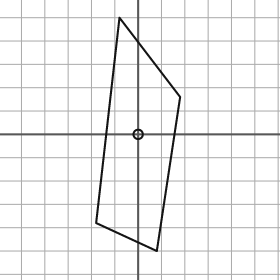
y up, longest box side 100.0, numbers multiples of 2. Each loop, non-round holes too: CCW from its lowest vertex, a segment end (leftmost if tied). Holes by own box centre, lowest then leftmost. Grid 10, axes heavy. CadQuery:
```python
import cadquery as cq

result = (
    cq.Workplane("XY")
    .moveTo(8.0, -50.0)
    .lineTo(18.0, 16.0)
    .lineTo(-8.0, 50.0)
    .lineTo(-18.0, -38.0)
    .close()
    .moveTo(0.0, 0.0)
    .circle(2.0)
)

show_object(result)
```